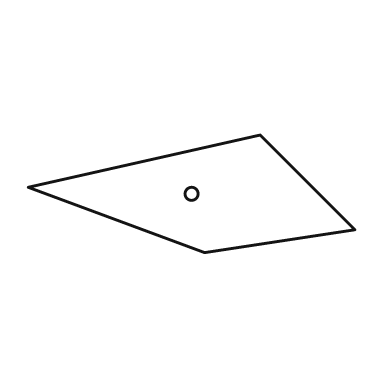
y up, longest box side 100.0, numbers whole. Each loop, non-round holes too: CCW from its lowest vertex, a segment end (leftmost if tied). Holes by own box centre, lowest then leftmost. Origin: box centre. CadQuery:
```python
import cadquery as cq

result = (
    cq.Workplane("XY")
    .moveTo(4.0, -18.0)
    .lineTo(50.0, -11.0)
    .lineTo(21.0, 18.0)
    .lineTo(-50.0, 2.0)
    .close()
    .moveTo(0.0, 0.0)
    .circle(2.0)
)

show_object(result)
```